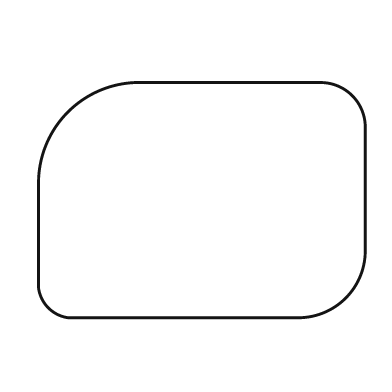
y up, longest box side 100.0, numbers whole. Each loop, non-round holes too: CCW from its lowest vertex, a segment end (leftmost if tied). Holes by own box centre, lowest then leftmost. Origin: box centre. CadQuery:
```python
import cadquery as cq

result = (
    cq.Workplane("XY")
    .moveTo(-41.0, -36.0)
    .lineTo(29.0, -36.0)
    .threePointArc((44.0, -30.0), (50.0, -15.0))
    .lineTo(50.0, 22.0)
    .threePointArc((46.0, 32.0), (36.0, 36.0))
    .lineTo(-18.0, 36.0)
    .threePointArc((-41.0, 27.0), (-50.0, 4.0))
    .lineTo(-50.0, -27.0)
    .threePointArc((-47.0, -33.0), (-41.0, -36.0))
    .close()
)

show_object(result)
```